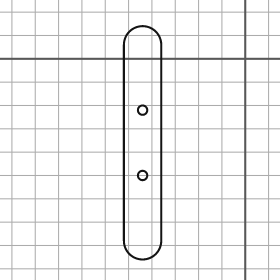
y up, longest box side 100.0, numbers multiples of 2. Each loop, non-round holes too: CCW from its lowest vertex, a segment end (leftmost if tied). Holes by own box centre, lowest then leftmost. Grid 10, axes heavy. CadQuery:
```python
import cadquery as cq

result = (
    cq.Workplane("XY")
    .moveTo(-52.0, -78.0)
    .threePointArc((-44.0, -86.0), (-36.0, -78.0))
    .lineTo(-36.0, 6.0)
    .threePointArc((-44.0, 14.0), (-52.0, 6.0))
    .close()
    .moveTo(-44.0, -50.0)
    .circle(2.0)
    .moveTo(-44.0, -22.0)
    .circle(2.0)
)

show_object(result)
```